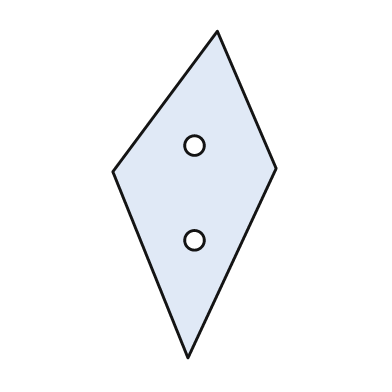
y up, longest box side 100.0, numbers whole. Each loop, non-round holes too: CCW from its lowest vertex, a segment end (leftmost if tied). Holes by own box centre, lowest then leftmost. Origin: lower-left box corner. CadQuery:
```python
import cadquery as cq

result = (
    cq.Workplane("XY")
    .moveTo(23.0, 0.0)
    .lineTo(50.0, 58.0)
    .lineTo(32.0, 100.0)
    .lineTo(0.0, 57.0)
    .close()
    .moveTo(25.0, 36.0)
    .circle(3.0)
    .moveTo(25.0, 65.0)
    .circle(3.0)
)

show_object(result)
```